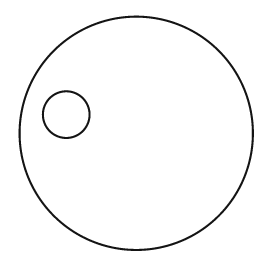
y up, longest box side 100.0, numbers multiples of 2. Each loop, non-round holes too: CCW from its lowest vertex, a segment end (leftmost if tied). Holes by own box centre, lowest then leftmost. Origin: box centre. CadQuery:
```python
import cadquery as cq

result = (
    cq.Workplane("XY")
    .moveTo(0.0, 0.0)
    .circle(50.0)
    .moveTo(-30.0, 8.0)
    .circle(10.0)
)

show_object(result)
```